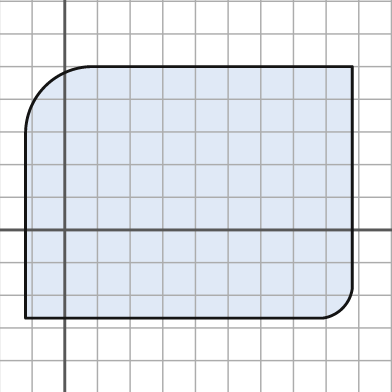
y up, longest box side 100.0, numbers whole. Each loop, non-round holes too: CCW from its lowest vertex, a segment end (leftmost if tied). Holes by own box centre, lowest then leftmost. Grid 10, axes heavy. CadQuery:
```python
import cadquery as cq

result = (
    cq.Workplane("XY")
    .moveTo(-12.0, -27.0)
    .lineTo(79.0, -27.0)
    .threePointArc((85.0, -24.0), (88.0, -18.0))
    .lineTo(88.0, 50.0)
    .lineTo(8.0, 50.0)
    .threePointArc((-6.0, 44.0), (-12.0, 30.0))
    .close()
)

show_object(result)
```